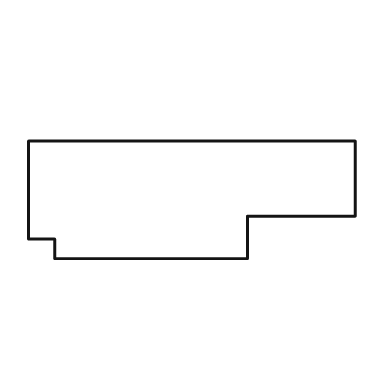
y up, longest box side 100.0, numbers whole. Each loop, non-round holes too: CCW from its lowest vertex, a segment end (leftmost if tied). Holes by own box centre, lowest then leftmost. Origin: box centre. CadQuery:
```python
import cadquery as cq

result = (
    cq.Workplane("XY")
    .moveTo(-42.0, -18.0)
    .lineTo(17.0, -18.0)
    .lineTo(17.0, -5.0)
    .lineTo(50.0, -5.0)
    .lineTo(50.0, 18.0)
    .lineTo(-50.0, 18.0)
    .lineTo(-50.0, -12.0)
    .lineTo(-42.0, -12.0)
    .close()
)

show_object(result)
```